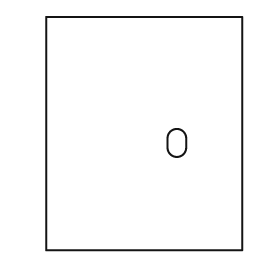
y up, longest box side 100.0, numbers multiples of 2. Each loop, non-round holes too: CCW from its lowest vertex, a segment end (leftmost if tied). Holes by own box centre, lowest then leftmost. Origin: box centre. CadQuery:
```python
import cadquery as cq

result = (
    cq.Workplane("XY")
    .moveTo(-42.0, -50.0)
    .lineTo(42.0, -50.0)
    .lineTo(42.0, 50.0)
    .lineTo(-42.0, 50.0)
    .close()
    .moveTo(10.0, -6.0)
    .threePointArc((14.0, -10.0), (18.0, -6.0))
    .lineTo(18.0, -2.0)
    .threePointArc((14.0, 2.0), (10.0, -2.0))
    .close()
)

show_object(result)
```